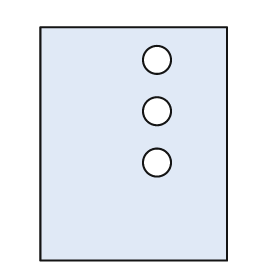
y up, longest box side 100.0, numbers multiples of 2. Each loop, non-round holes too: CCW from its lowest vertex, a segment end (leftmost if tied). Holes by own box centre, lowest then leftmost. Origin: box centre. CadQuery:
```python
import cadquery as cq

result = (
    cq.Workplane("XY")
    .moveTo(-40.0, -50.0)
    .lineTo(40.0, -50.0)
    .lineTo(40.0, 50.0)
    .lineTo(-40.0, 50.0)
    .close()
    .moveTo(10.0, -8.0)
    .circle(6.0)
    .moveTo(10.0, 14.0)
    .circle(6.0)
    .moveTo(10.0, 36.0)
    .circle(6.0)
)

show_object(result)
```